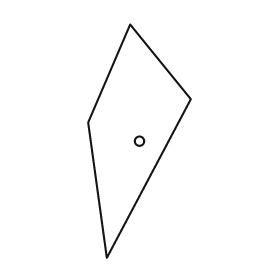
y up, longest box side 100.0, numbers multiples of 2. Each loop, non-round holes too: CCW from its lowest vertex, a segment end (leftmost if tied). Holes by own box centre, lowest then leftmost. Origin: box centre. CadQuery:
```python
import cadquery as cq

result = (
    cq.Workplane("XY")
    .moveTo(-14.0, -50.0)
    .lineTo(22.0, 18.0)
    .lineTo(-4.0, 50.0)
    .lineTo(-22.0, 8.0)
    .close()
    .moveTo(0.0, 0.0)
    .circle(2.0)
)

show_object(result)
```